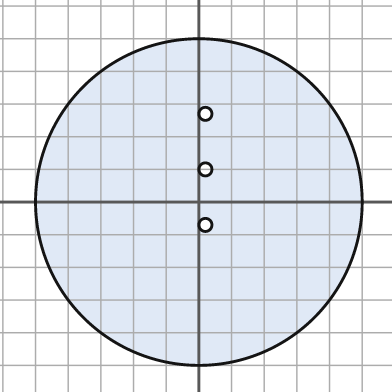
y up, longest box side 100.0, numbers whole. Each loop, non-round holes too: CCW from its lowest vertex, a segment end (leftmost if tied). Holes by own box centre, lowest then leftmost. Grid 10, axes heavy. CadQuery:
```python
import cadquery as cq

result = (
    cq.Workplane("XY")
    .moveTo(0.0, 0.0)
    .circle(50.0)
    .moveTo(2.0, -7.0)
    .circle(2.0)
    .moveTo(2.0, 10.0)
    .circle(2.0)
    .moveTo(2.0, 27.0)
    .circle(2.0)
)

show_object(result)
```